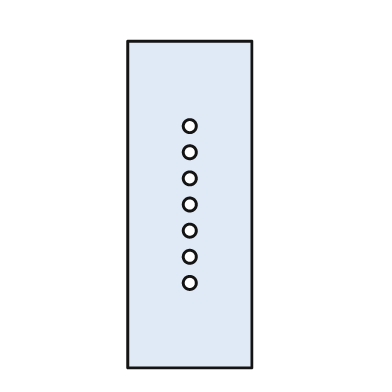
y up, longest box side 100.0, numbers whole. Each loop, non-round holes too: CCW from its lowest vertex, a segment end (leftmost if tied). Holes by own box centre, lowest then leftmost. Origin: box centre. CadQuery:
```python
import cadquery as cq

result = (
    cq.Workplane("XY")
    .moveTo(-19.0, -50.0)
    .lineTo(19.0, -50.0)
    .lineTo(19.0, 50.0)
    .lineTo(-19.0, 50.0)
    .close()
    .moveTo(0.0, -24.0)
    .circle(2.0)
    .moveTo(0.0, -16.0)
    .circle(2.0)
    .moveTo(0.0, -8.0)
    .circle(2.0)
    .moveTo(0.0, 0.0)
    .circle(2.0)
    .moveTo(0.0, 8.0)
    .circle(2.0)
    .moveTo(0.0, 16.0)
    .circle(2.0)
    .moveTo(0.0, 24.0)
    .circle(2.0)
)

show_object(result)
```